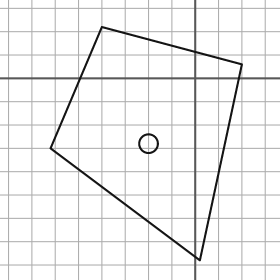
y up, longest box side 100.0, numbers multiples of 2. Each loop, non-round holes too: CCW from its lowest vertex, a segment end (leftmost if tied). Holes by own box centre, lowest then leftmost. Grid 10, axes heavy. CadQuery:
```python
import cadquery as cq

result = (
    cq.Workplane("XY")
    .moveTo(2.0, -78.0)
    .lineTo(20.0, 6.0)
    .lineTo(-40.0, 22.0)
    .lineTo(-62.0, -30.0)
    .close()
    .moveTo(-20.0, -28.0)
    .circle(4.0)
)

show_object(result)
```